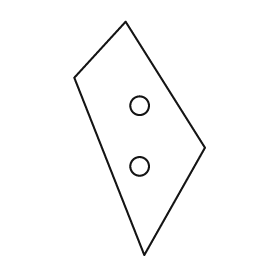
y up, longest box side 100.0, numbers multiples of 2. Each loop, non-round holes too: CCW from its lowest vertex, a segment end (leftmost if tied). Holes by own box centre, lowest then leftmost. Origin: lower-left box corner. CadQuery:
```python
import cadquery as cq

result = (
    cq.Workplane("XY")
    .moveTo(30.0, 0.0)
    .lineTo(56.0, 46.0)
    .lineTo(22.0, 100.0)
    .lineTo(0.0, 76.0)
    .close()
    .moveTo(28.0, 38.0)
    .circle(4.0)
    .moveTo(28.0, 64.0)
    .circle(4.0)
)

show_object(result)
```